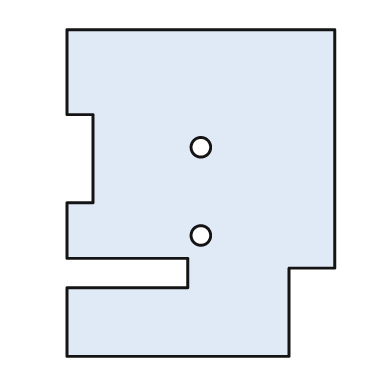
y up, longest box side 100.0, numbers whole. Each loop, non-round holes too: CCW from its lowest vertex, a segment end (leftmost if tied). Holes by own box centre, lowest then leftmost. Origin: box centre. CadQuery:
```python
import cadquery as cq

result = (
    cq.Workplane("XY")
    .moveTo(-41.0, -50.0)
    .lineTo(27.0, -50.0)
    .lineTo(27.0, -23.0)
    .lineTo(41.0, -23.0)
    .lineTo(41.0, 50.0)
    .lineTo(-41.0, 50.0)
    .lineTo(-41.0, 24.0)
    .lineTo(-33.0, 24.0)
    .lineTo(-33.0, -3.0)
    .lineTo(-41.0, -3.0)
    .lineTo(-41.0, -20.0)
    .lineTo(-4.0, -20.0)
    .lineTo(-4.0, -29.0)
    .lineTo(-41.0, -29.0)
    .close()
    .moveTo(0.0, -13.0)
    .circle(3.0)
    .moveTo(0.0, 14.0)
    .circle(3.0)
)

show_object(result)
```